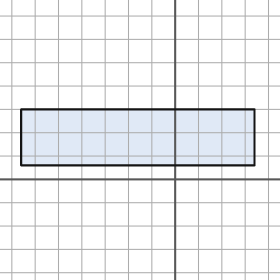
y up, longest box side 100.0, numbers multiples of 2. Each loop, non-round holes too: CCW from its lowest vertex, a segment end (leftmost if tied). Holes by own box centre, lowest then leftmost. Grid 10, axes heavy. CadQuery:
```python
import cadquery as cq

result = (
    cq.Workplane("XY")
    .moveTo(-66.0, 6.0)
    .lineTo(34.0, 6.0)
    .lineTo(34.0, 30.0)
    .lineTo(-66.0, 30.0)
    .close()
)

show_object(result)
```